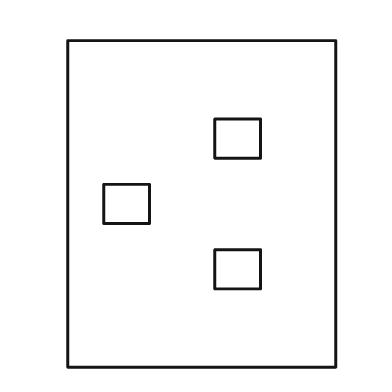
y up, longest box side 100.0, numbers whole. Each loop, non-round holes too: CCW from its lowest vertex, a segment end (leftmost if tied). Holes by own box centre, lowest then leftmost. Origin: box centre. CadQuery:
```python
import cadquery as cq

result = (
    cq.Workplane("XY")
    .moveTo(-41.0, -50.0)
    .lineTo(41.0, -50.0)
    .lineTo(41.0, 50.0)
    .lineTo(-41.0, 50.0)
    .close()
    .moveTo(4.0, -26.0)
    .lineTo(18.0, -26.0)
    .lineTo(18.0, -14.0)
    .lineTo(4.0, -14.0)
    .close()
    .moveTo(-30.0, -6.0)
    .lineTo(-16.0, -6.0)
    .lineTo(-16.0, 6.0)
    .lineTo(-30.0, 6.0)
    .close()
    .moveTo(4.0, 14.0)
    .lineTo(18.0, 14.0)
    .lineTo(18.0, 26.0)
    .lineTo(4.0, 26.0)
    .close()
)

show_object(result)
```